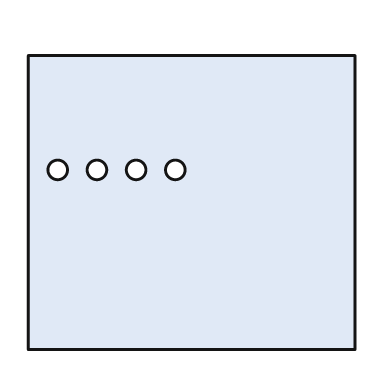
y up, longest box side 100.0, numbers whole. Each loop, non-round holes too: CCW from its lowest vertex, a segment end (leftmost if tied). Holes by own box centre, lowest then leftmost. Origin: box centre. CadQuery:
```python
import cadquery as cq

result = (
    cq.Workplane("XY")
    .moveTo(-50.0, -45.0)
    .lineTo(50.0, -45.0)
    .lineTo(50.0, 45.0)
    .lineTo(-50.0, 45.0)
    .close()
    .moveTo(-41.0, 10.0)
    .circle(3.0)
    .moveTo(-29.0, 10.0)
    .circle(3.0)
    .moveTo(-17.0, 10.0)
    .circle(3.0)
    .moveTo(-5.0, 10.0)
    .circle(3.0)
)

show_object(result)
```